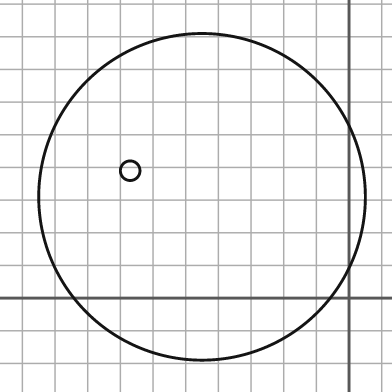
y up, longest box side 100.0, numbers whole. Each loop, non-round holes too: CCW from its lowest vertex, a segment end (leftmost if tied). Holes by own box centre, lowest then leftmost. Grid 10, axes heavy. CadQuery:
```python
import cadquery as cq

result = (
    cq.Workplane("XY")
    .moveTo(-45.0, 31.0)
    .circle(50.0)
    .moveTo(-67.0, 39.0)
    .circle(3.0)
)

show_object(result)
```